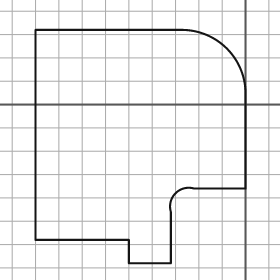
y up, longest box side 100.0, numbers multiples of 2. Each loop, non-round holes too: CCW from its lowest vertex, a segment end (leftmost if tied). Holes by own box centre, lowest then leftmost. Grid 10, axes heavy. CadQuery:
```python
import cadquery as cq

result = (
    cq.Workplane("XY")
    .moveTo(-50.0, -68.0)
    .lineTo(-32.0, -68.0)
    .lineTo(-32.0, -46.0)
    .threePointArc((-30.0, -38.0), (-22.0, -36.0))
    .lineTo(0.0, -36.0)
    .lineTo(0.0, 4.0)
    .threePointArc((-8.0, 24.0), (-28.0, 32.0))
    .lineTo(-90.0, 32.0)
    .lineTo(-90.0, -58.0)
    .lineTo(-50.0, -58.0)
    .close()
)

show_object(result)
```